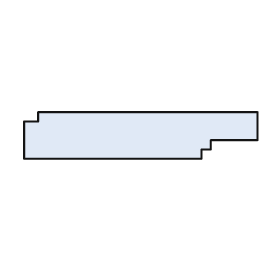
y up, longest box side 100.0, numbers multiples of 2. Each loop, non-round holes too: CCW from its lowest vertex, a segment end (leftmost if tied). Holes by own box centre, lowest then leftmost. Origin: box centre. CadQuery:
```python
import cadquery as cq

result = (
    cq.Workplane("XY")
    .moveTo(-50.0, -10.0)
    .lineTo(26.0, -10.0)
    .lineTo(26.0, -6.0)
    .lineTo(30.0, -6.0)
    .lineTo(30.0, -2.0)
    .lineTo(50.0, -2.0)
    .lineTo(50.0, 10.0)
    .lineTo(-44.0, 10.0)
    .lineTo(-44.0, 6.0)
    .lineTo(-50.0, 6.0)
    .close()
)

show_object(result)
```